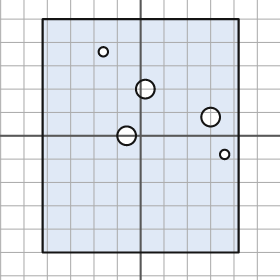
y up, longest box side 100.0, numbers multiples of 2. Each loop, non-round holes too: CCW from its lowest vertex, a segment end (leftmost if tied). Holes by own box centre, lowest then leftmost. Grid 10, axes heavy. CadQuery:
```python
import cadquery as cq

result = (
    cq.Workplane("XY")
    .moveTo(-42.0, -50.0)
    .lineTo(42.0, -50.0)
    .lineTo(42.0, 50.0)
    .lineTo(-42.0, 50.0)
    .close()
    .moveTo(36.0, -8.0)
    .circle(2.0)
    .moveTo(-6.0, 0.0)
    .circle(4.0)
    .moveTo(30.0, 8.0)
    .circle(4.0)
    .moveTo(2.0, 20.0)
    .circle(4.0)
    .moveTo(-16.0, 36.0)
    .circle(2.0)
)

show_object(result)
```